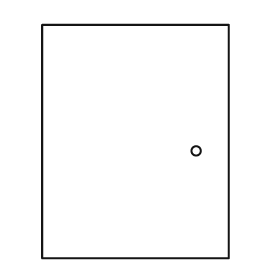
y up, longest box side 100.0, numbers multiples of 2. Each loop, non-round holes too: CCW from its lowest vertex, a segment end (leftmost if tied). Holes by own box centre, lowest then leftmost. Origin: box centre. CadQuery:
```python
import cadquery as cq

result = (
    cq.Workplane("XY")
    .moveTo(-40.0, -50.0)
    .lineTo(40.0, -50.0)
    .lineTo(40.0, 50.0)
    .lineTo(-40.0, 50.0)
    .close()
    .moveTo(26.0, -4.0)
    .circle(2.0)
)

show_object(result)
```